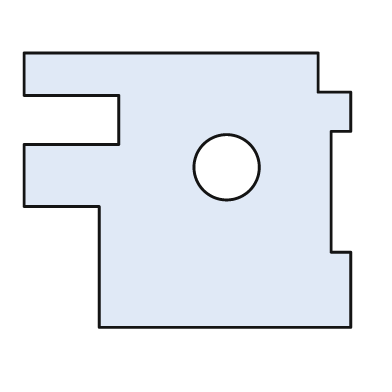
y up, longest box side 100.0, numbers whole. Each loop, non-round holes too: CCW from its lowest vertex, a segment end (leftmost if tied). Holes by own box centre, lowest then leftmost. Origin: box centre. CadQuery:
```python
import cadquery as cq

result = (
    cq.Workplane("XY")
    .moveTo(-27.0, -42.0)
    .lineTo(50.0, -42.0)
    .lineTo(50.0, -19.0)
    .lineTo(44.0, -19.0)
    .lineTo(44.0, 18.0)
    .lineTo(50.0, 18.0)
    .lineTo(50.0, 30.0)
    .lineTo(40.0, 30.0)
    .lineTo(40.0, 42.0)
    .lineTo(-50.0, 42.0)
    .lineTo(-50.0, 29.0)
    .lineTo(-21.0, 29.0)
    .lineTo(-21.0, 14.0)
    .lineTo(-50.0, 14.0)
    .lineTo(-50.0, -5.0)
    .lineTo(-27.0, -5.0)
    .close()
    .moveTo(12.0, 7.0)
    .circle(10.0)
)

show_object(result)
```